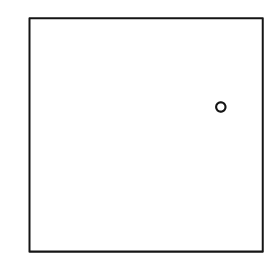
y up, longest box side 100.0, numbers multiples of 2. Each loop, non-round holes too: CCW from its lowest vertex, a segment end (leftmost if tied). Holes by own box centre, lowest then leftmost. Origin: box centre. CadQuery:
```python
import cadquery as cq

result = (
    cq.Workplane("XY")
    .moveTo(-50.0, -50.0)
    .lineTo(50.0, -50.0)
    .lineTo(50.0, 50.0)
    .lineTo(-50.0, 50.0)
    .close()
    .moveTo(32.0, 12.0)
    .circle(2.0)
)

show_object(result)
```